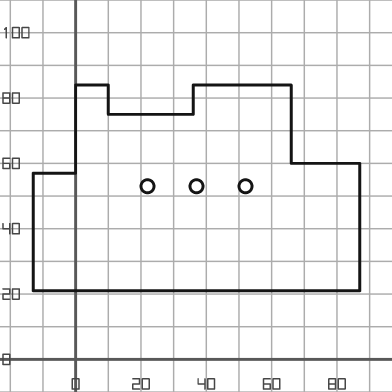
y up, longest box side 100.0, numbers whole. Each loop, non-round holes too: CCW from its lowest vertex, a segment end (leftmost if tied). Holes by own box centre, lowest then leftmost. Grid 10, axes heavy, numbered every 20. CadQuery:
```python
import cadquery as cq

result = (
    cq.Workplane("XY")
    .moveTo(-13.0, 21.0)
    .lineTo(87.0, 21.0)
    .lineTo(87.0, 60.0)
    .lineTo(66.0, 60.0)
    .lineTo(66.0, 84.0)
    .lineTo(36.0, 84.0)
    .lineTo(36.0, 75.0)
    .lineTo(10.0, 75.0)
    .lineTo(10.0, 84.0)
    .lineTo(0.0, 84.0)
    .lineTo(0.0, 57.0)
    .lineTo(-13.0, 57.0)
    .close()
    .moveTo(22.0, 53.0)
    .circle(2.0)
    .moveTo(37.0, 53.0)
    .circle(2.0)
    .moveTo(52.0, 53.0)
    .circle(2.0)
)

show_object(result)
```